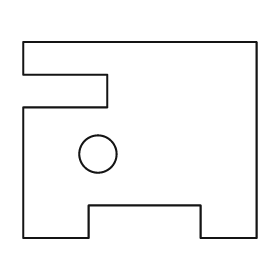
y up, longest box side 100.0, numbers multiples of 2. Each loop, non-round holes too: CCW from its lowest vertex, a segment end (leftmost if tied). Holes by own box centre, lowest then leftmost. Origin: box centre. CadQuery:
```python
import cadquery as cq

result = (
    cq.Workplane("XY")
    .moveTo(-50.0, -42.0)
    .lineTo(-22.0, -42.0)
    .lineTo(-22.0, -28.0)
    .lineTo(26.0, -28.0)
    .lineTo(26.0, -42.0)
    .lineTo(50.0, -42.0)
    .lineTo(50.0, 42.0)
    .lineTo(-50.0, 42.0)
    .lineTo(-50.0, 28.0)
    .lineTo(-14.0, 28.0)
    .lineTo(-14.0, 14.0)
    .lineTo(-50.0, 14.0)
    .close()
    .moveTo(-18.0, -6.0)
    .circle(8.0)
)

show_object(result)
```